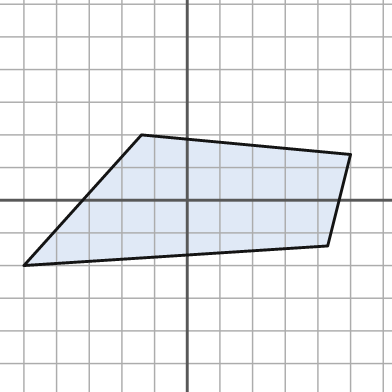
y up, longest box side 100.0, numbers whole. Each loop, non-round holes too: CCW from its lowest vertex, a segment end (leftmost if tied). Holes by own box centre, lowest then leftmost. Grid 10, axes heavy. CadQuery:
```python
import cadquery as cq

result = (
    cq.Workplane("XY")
    .moveTo(-50.0, -20.0)
    .lineTo(43.0, -14.0)
    .lineTo(50.0, 14.0)
    .lineTo(-14.0, 20.0)
    .close()
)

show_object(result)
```